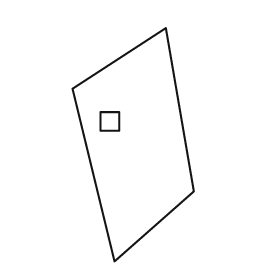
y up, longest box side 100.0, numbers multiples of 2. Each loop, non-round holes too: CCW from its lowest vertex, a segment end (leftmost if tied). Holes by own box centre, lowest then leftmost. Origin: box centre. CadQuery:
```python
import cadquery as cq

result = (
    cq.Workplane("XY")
    .moveTo(-8.0, -50.0)
    .lineTo(26.0, -20.0)
    .lineTo(14.0, 50.0)
    .lineTo(-26.0, 24.0)
    .close()
    .moveTo(-14.0, 6.0)
    .lineTo(-6.0, 6.0)
    .lineTo(-6.0, 14.0)
    .lineTo(-14.0, 14.0)
    .close()
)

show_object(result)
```